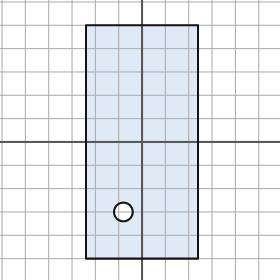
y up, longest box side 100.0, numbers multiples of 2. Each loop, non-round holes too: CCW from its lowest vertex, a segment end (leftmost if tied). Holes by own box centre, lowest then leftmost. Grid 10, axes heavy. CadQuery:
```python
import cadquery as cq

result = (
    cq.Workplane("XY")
    .moveTo(-24.0, -50.0)
    .lineTo(24.0, -50.0)
    .lineTo(24.0, 50.0)
    .lineTo(-24.0, 50.0)
    .close()
    .moveTo(-8.0, -30.0)
    .circle(4.0)
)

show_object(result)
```